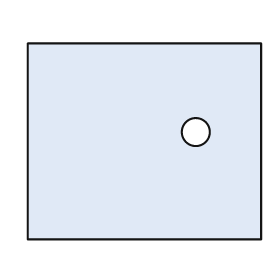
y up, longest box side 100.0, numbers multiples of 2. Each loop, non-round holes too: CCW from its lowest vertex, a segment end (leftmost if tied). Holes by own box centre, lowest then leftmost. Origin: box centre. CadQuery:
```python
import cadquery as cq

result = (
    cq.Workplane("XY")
    .moveTo(-50.0, -42.0)
    .lineTo(50.0, -42.0)
    .lineTo(50.0, 42.0)
    .lineTo(-50.0, 42.0)
    .close()
    .moveTo(22.0, 4.0)
    .circle(6.0)
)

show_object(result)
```